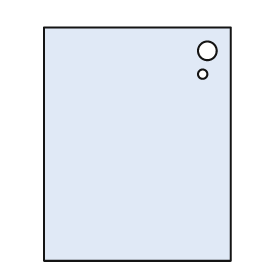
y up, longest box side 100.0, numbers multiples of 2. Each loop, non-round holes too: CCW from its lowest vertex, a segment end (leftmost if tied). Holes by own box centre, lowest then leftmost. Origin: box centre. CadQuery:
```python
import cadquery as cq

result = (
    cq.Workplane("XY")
    .moveTo(-40.0, -50.0)
    .lineTo(40.0, -50.0)
    .lineTo(40.0, 50.0)
    .lineTo(-40.0, 50.0)
    .close()
    .moveTo(28.0, 30.0)
    .circle(2.0)
    .moveTo(30.0, 40.0)
    .circle(4.0)
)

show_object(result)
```